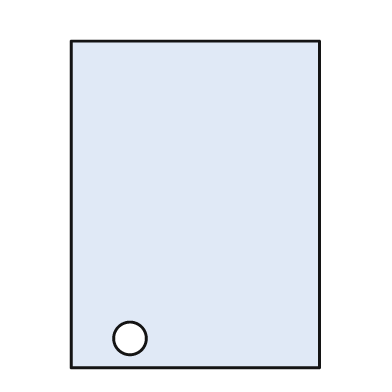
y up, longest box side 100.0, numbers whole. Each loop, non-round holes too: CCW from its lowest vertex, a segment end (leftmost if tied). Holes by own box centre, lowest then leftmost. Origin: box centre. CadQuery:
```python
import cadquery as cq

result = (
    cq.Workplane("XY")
    .moveTo(-38.0, -50.0)
    .lineTo(38.0, -50.0)
    .lineTo(38.0, 50.0)
    .lineTo(-38.0, 50.0)
    .close()
    .moveTo(-20.0, -41.0)
    .circle(5.0)
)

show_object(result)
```